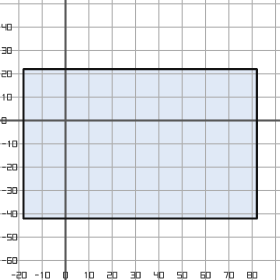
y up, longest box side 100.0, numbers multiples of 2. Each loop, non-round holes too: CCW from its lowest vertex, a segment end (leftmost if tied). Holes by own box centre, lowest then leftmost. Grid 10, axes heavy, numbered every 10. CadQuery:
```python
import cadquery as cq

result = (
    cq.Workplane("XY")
    .moveTo(-18.0, -42.0)
    .lineTo(82.0, -42.0)
    .lineTo(82.0, 22.0)
    .lineTo(-18.0, 22.0)
    .close()
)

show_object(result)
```